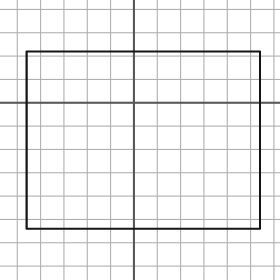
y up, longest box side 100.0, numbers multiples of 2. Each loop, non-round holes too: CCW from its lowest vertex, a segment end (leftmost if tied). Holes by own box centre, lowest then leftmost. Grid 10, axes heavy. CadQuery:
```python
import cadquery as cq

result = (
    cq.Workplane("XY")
    .moveTo(-46.0, -54.0)
    .lineTo(54.0, -54.0)
    .lineTo(54.0, 22.0)
    .lineTo(-46.0, 22.0)
    .close()
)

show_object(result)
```